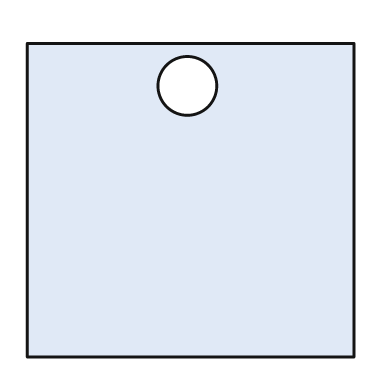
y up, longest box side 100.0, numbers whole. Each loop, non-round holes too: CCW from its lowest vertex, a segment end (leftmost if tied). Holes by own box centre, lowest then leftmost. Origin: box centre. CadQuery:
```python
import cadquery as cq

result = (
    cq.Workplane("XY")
    .moveTo(-50.0, -48.0)
    .lineTo(50.0, -48.0)
    .lineTo(50.0, 48.0)
    .lineTo(-50.0, 48.0)
    .close()
    .moveTo(-1.0, 35.0)
    .circle(9.0)
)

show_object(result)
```